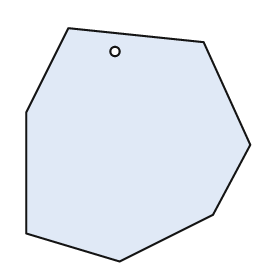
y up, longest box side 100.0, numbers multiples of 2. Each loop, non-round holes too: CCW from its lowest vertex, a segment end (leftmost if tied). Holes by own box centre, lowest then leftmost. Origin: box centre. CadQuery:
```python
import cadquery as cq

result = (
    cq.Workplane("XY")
    .moveTo(-8.0, -50.0)
    .lineTo(32.0, -30.0)
    .lineTo(48.0, 0.0)
    .lineTo(28.0, 44.0)
    .lineTo(-30.0, 50.0)
    .lineTo(-48.0, 14.0)
    .lineTo(-48.0, -38.0)
    .close()
    .moveTo(-10.0, 40.0)
    .circle(2.0)
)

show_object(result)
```